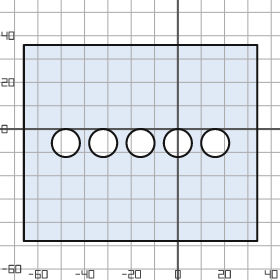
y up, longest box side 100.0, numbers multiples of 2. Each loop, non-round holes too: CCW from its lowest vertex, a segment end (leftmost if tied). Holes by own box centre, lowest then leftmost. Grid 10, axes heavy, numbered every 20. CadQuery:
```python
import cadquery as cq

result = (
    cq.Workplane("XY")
    .moveTo(-66.0, -48.0)
    .lineTo(34.0, -48.0)
    .lineTo(34.0, 36.0)
    .lineTo(-66.0, 36.0)
    .close()
    .moveTo(-48.0, -6.0)
    .circle(6.0)
    .moveTo(-32.0, -6.0)
    .circle(6.0)
    .moveTo(-16.0, -6.0)
    .circle(6.0)
    .moveTo(0.0, -6.0)
    .circle(6.0)
    .moveTo(16.0, -6.0)
    .circle(6.0)
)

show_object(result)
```